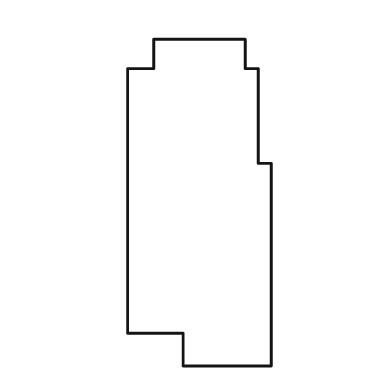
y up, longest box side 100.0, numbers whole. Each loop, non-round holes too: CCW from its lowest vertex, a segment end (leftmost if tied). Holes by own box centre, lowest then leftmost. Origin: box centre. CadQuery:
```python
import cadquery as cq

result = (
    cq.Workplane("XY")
    .moveTo(-5.0, -50.0)
    .lineTo(22.0, -50.0)
    .lineTo(22.0, 12.0)
    .lineTo(18.0, 12.0)
    .lineTo(18.0, 41.0)
    .lineTo(14.0, 41.0)
    .lineTo(14.0, 50.0)
    .lineTo(-14.0, 50.0)
    .lineTo(-14.0, 41.0)
    .lineTo(-22.0, 41.0)
    .lineTo(-22.0, -40.0)
    .lineTo(-5.0, -40.0)
    .close()
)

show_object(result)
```